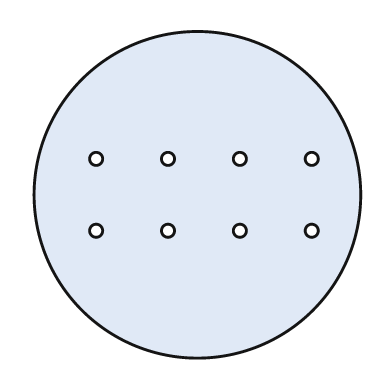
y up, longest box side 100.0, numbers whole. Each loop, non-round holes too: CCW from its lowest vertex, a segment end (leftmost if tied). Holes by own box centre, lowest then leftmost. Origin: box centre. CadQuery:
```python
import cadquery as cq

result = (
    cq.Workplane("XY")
    .moveTo(0.0, 0.0)
    .circle(50.0)
    .moveTo(-31.0, -11.0)
    .circle(2.0)
    .moveTo(-9.0, -11.0)
    .circle(2.0)
    .moveTo(13.0, -11.0)
    .circle(2.0)
    .moveTo(35.0, -11.0)
    .circle(2.0)
    .moveTo(-31.0, 11.0)
    .circle(2.0)
    .moveTo(-9.0, 11.0)
    .circle(2.0)
    .moveTo(13.0, 11.0)
    .circle(2.0)
    .moveTo(35.0, 11.0)
    .circle(2.0)
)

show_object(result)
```